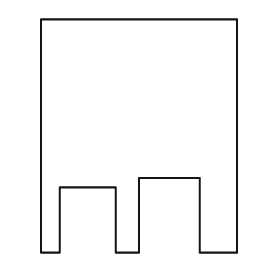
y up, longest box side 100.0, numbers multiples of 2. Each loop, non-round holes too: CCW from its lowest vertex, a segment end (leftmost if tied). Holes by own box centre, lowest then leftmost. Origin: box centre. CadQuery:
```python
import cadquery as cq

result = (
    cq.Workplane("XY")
    .moveTo(-42.0, -50.0)
    .lineTo(-34.0, -50.0)
    .lineTo(-34.0, -22.0)
    .lineTo(-10.0, -22.0)
    .lineTo(-10.0, -50.0)
    .lineTo(0.0, -50.0)
    .lineTo(0.0, -18.0)
    .lineTo(26.0, -18.0)
    .lineTo(26.0, -50.0)
    .lineTo(42.0, -50.0)
    .lineTo(42.0, 50.0)
    .lineTo(-42.0, 50.0)
    .close()
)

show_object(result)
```